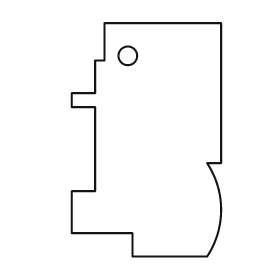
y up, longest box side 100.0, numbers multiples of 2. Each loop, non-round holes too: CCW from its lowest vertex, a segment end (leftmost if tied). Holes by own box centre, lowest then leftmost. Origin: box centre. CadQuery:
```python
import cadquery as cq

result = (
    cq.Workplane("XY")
    .moveTo(-6.0, -50.0)
    .lineTo(26.0, -50.0)
    .threePointArc((32.0, -30.0), (26.0, -10.0))
    .lineTo(32.0, -10.0)
    .lineTo(32.0, 50.0)
    .lineTo(-18.0, 50.0)
    .lineTo(-18.0, 34.0)
    .lineTo(-22.0, 34.0)
    .lineTo(-22.0, 20.0)
    .lineTo(-32.0, 20.0)
    .lineTo(-32.0, 14.0)
    .lineTo(-22.0, 14.0)
    .lineTo(-22.0, -22.0)
    .lineTo(-32.0, -22.0)
    .lineTo(-32.0, -40.0)
    .lineTo(-6.0, -40.0)
    .close()
    .moveTo(-8.0, 36.0)
    .circle(4.0)
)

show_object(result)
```